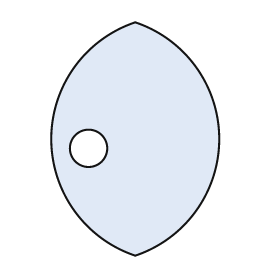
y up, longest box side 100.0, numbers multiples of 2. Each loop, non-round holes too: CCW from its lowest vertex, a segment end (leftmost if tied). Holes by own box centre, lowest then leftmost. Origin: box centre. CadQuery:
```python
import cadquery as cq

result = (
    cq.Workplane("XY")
    .moveTo(0.0, -50.0)
    .threePointArc((36.0, 0.0), (0.0, 50.0))
    .threePointArc((-36.0, 0.0), (0.0, -50.0))
    .close()
    .moveTo(-20.0, -4.0)
    .circle(8.0)
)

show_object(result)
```